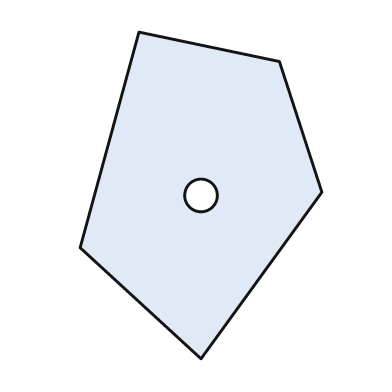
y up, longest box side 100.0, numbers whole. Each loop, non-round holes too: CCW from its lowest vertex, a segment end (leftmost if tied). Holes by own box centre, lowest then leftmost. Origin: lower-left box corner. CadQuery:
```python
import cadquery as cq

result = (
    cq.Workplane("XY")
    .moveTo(37.0, 0.0)
    .lineTo(74.0, 51.0)
    .lineTo(61.0, 91.0)
    .lineTo(18.0, 100.0)
    .lineTo(0.0, 34.0)
    .close()
    .moveTo(37.0, 50.0)
    .circle(5.0)
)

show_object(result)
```